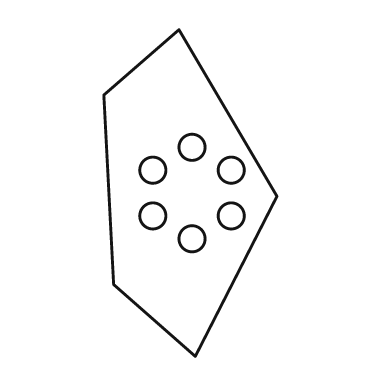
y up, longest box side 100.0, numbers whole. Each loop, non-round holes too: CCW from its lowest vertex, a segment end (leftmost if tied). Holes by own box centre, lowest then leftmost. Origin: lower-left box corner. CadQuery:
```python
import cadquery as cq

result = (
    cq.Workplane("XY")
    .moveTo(28.0, 0.0)
    .lineTo(53.0, 49.0)
    .lineTo(23.0, 100.0)
    .lineTo(0.0, 80.0)
    .lineTo(3.0, 22.0)
    .close()
    .moveTo(27.0, 36.0)
    .circle(4.0)
    .moveTo(15.0, 43.0)
    .circle(4.0)
    .moveTo(39.0, 43.0)
    .circle(4.0)
    .moveTo(15.0, 57.0)
    .circle(4.0)
    .moveTo(39.0, 57.0)
    .circle(4.0)
    .moveTo(27.0, 64.0)
    .circle(4.0)
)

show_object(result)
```